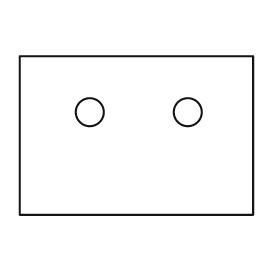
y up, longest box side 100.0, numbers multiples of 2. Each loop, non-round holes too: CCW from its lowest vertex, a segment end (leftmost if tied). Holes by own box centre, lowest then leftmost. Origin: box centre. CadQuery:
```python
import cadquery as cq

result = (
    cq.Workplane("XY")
    .moveTo(-50.0, -34.0)
    .lineTo(50.0, -34.0)
    .lineTo(50.0, 34.0)
    .lineTo(-50.0, 34.0)
    .close()
    .moveTo(-20.0, 10.0)
    .circle(6.0)
    .moveTo(22.0, 10.0)
    .circle(6.0)
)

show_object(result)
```